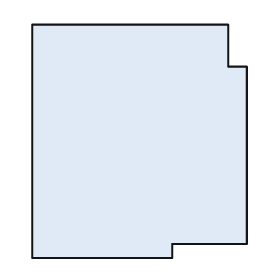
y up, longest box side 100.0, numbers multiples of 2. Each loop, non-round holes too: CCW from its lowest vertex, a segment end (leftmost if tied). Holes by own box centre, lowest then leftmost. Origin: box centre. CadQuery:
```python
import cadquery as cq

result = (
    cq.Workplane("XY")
    .moveTo(-46.0, -50.0)
    .lineTo(14.0, -50.0)
    .lineTo(14.0, -44.0)
    .lineTo(46.0, -44.0)
    .lineTo(46.0, 32.0)
    .lineTo(38.0, 32.0)
    .lineTo(38.0, 50.0)
    .lineTo(-46.0, 50.0)
    .close()
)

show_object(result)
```